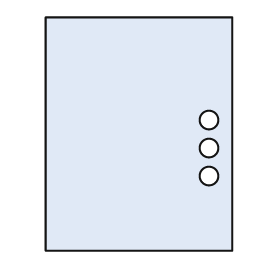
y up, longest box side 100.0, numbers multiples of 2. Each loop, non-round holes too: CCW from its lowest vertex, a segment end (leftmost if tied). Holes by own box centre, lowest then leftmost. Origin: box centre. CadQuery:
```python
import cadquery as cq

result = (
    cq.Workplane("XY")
    .moveTo(-40.0, -50.0)
    .lineTo(40.0, -50.0)
    .lineTo(40.0, 50.0)
    .lineTo(-40.0, 50.0)
    .close()
    .moveTo(30.0, -18.0)
    .circle(4.0)
    .moveTo(30.0, -6.0)
    .circle(4.0)
    .moveTo(30.0, 6.0)
    .circle(4.0)
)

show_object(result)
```